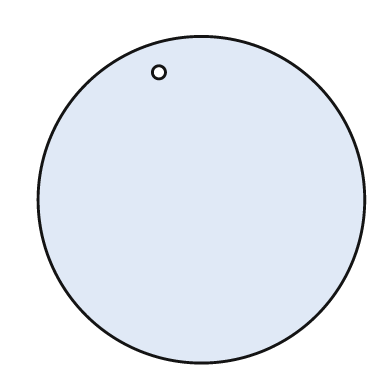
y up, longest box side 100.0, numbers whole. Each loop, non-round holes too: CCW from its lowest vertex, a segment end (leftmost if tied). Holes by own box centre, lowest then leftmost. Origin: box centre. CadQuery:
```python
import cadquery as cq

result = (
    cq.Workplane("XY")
    .moveTo(0.0, 0.0)
    .circle(50.0)
    .moveTo(-13.0, 39.0)
    .circle(2.0)
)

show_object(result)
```